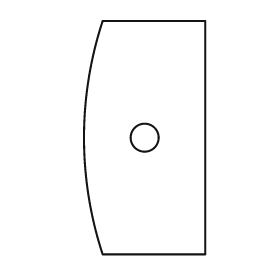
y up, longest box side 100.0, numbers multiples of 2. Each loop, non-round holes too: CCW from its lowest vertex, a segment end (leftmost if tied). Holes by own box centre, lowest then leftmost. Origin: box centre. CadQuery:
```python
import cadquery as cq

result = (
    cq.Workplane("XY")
    .moveTo(-18.0, -50.0)
    .lineTo(26.0, -50.0)
    .lineTo(26.0, 50.0)
    .lineTo(-18.0, 50.0)
    .threePointArc((-26.0, 0.0), (-18.0, -50.0))
    .close()
    .moveTo(0.0, 0.0)
    .circle(6.0)
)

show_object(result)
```